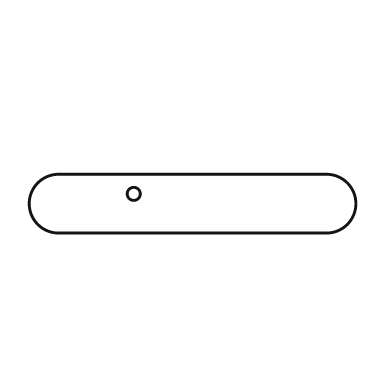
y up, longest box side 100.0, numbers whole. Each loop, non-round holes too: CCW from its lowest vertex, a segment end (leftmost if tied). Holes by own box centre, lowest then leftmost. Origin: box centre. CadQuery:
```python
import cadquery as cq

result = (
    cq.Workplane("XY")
    .moveTo(-41.0, -9.0)
    .lineTo(41.0, -9.0)
    .threePointArc((50.0, 0.0), (41.0, 9.0))
    .lineTo(-41.0, 9.0)
    .threePointArc((-50.0, 0.0), (-41.0, -9.0))
    .close()
    .moveTo(-18.0, 3.0)
    .circle(2.0)
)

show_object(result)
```